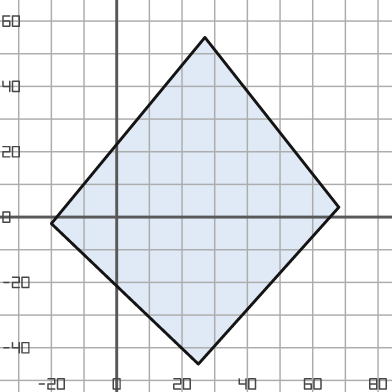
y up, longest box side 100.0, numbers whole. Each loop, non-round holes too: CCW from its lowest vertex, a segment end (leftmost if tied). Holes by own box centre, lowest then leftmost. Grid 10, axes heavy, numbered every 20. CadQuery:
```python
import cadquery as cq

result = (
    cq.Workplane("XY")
    .moveTo(25.0, -45.0)
    .lineTo(68.0, 3.0)
    .lineTo(27.0, 55.0)
    .lineTo(-20.0, -2.0)
    .close()
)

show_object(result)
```